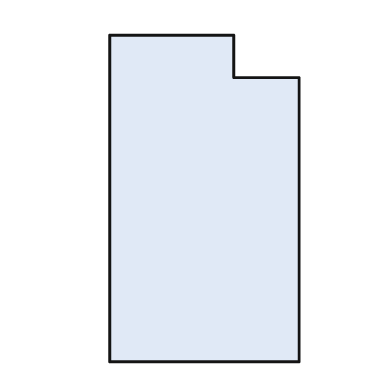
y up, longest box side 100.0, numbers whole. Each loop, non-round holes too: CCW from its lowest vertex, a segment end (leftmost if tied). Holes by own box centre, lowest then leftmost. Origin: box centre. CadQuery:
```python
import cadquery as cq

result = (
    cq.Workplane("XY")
    .moveTo(-29.0, -50.0)
    .lineTo(29.0, -50.0)
    .lineTo(29.0, 37.0)
    .lineTo(9.0, 37.0)
    .lineTo(9.0, 50.0)
    .lineTo(-29.0, 50.0)
    .close()
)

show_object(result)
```